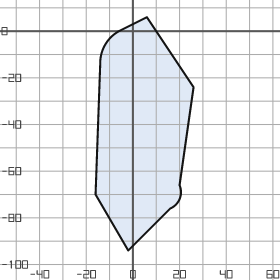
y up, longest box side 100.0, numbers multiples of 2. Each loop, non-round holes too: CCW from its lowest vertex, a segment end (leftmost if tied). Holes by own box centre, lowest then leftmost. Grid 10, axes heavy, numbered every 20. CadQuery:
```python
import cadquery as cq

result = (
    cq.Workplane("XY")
    .moveTo(-2.0, -94.0)
    .lineTo(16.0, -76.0)
    .threePointArc((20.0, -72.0), (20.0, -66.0))
    .lineTo(26.0, -24.0)
    .lineTo(6.0, 6.0)
    .lineTo(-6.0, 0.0)
    .threePointArc((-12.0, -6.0), (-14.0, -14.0))
    .lineTo(-16.0, -70.0)
    .close()
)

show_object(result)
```